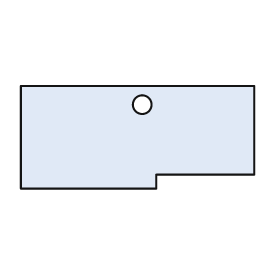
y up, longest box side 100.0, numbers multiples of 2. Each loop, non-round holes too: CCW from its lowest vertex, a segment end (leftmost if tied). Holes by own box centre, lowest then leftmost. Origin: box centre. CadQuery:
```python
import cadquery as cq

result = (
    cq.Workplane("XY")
    .moveTo(-50.0, -22.0)
    .lineTo(8.0, -22.0)
    .lineTo(8.0, -16.0)
    .lineTo(50.0, -16.0)
    .lineTo(50.0, 22.0)
    .lineTo(-50.0, 22.0)
    .close()
    .moveTo(2.0, 14.0)
    .circle(4.0)
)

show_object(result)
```